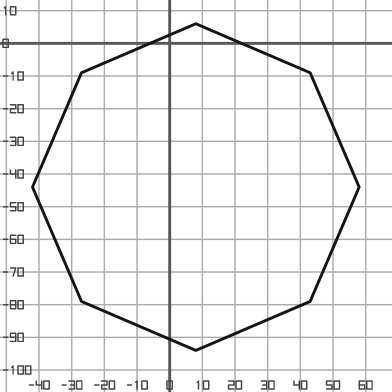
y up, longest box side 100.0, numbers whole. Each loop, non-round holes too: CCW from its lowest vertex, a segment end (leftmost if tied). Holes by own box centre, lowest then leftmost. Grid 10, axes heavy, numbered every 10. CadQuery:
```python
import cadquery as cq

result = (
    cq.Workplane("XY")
    .moveTo(8.0, -94.0)
    .lineTo(43.0, -79.0)
    .lineTo(58.0, -44.0)
    .lineTo(43.0, -9.0)
    .lineTo(8.0, 6.0)
    .lineTo(-27.0, -9.0)
    .lineTo(-42.0, -44.0)
    .lineTo(-27.0, -79.0)
    .close()
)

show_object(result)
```